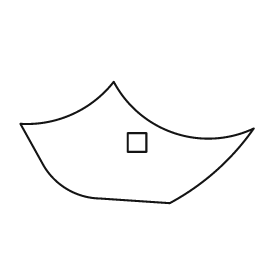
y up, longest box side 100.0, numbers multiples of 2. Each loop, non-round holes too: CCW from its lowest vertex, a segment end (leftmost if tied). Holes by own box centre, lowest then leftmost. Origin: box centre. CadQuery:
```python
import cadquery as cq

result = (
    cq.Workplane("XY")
    .moveTo(14.0, -26.0)
    .threePointArc((34.0, -12.0), (50.0, 6.0))
    .threePointArc((16.0, 4.0), (-10.0, 26.0))
    .threePointArc((-28.0, 12.0), (-50.0, 8.0))
    .lineTo(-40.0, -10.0)
    .threePointArc((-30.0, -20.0), (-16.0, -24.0))
    .close()
    .moveTo(-4.0, -4.0)
    .lineTo(4.0, -4.0)
    .lineTo(4.0, 4.0)
    .lineTo(-4.0, 4.0)
    .close()
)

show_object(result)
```